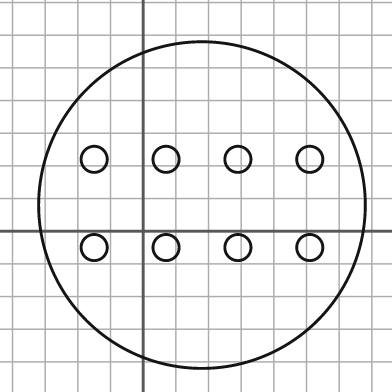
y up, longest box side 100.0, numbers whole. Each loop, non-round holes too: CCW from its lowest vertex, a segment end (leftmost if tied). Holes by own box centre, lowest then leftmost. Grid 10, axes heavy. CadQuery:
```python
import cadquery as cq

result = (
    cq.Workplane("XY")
    .moveTo(18.0, 8.0)
    .circle(50.0)
    .moveTo(-15.0, -5.0)
    .circle(4.0)
    .moveTo(7.0, -5.0)
    .circle(4.0)
    .moveTo(29.0, -5.0)
    .circle(4.0)
    .moveTo(51.0, -5.0)
    .circle(4.0)
    .moveTo(-15.0, 22.0)
    .circle(4.0)
    .moveTo(7.0, 22.0)
    .circle(4.0)
    .moveTo(29.0, 22.0)
    .circle(4.0)
    .moveTo(51.0, 22.0)
    .circle(4.0)
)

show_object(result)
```